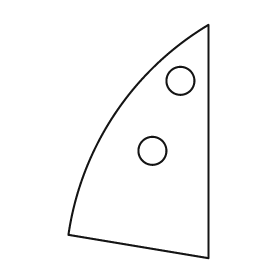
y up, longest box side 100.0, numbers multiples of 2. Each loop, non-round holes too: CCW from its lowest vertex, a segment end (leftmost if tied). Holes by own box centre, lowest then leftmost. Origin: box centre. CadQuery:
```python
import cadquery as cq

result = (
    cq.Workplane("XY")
    .moveTo(30.0, -50.0)
    .lineTo(30.0, 50.0)
    .threePointArc((-10.0, 12.0), (-30.0, -40.0))
    .close()
    .moveTo(6.0, -4.0)
    .circle(6.0)
    .moveTo(18.0, 26.0)
    .circle(6.0)
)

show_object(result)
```